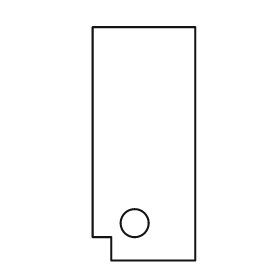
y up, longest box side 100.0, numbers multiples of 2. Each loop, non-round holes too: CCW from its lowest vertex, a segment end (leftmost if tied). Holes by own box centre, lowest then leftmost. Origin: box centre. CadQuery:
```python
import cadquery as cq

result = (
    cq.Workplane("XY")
    .moveTo(-14.0, -50.0)
    .lineTo(22.0, -50.0)
    .lineTo(22.0, 50.0)
    .lineTo(-22.0, 50.0)
    .lineTo(-22.0, -40.0)
    .lineTo(-14.0, -40.0)
    .close()
    .moveTo(-4.0, -34.0)
    .circle(6.0)
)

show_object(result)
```